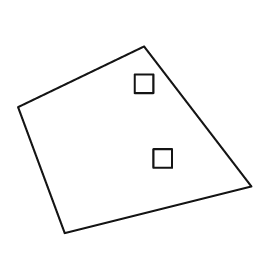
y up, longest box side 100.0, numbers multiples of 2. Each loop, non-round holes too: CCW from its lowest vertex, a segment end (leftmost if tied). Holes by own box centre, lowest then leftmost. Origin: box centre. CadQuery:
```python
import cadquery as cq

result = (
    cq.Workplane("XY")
    .moveTo(-30.0, -40.0)
    .lineTo(50.0, -20.0)
    .lineTo(4.0, 40.0)
    .lineTo(-50.0, 14.0)
    .close()
    .moveTo(8.0, -12.0)
    .lineTo(16.0, -12.0)
    .lineTo(16.0, -4.0)
    .lineTo(8.0, -4.0)
    .close()
    .moveTo(0.0, 20.0)
    .lineTo(8.0, 20.0)
    .lineTo(8.0, 28.0)
    .lineTo(0.0, 28.0)
    .close()
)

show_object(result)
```